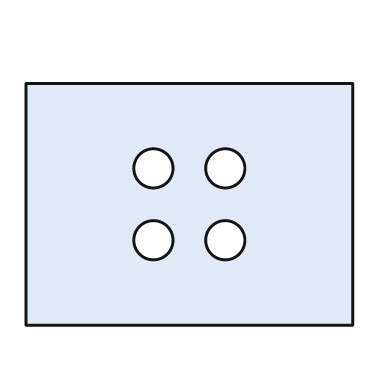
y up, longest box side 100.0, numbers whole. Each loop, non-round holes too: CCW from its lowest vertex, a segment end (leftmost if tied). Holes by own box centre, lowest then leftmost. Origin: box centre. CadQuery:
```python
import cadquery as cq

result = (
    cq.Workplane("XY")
    .moveTo(-50.0, -37.0)
    .lineTo(50.0, -37.0)
    .lineTo(50.0, 37.0)
    .lineTo(-50.0, 37.0)
    .close()
    .moveTo(-11.0, -11.0)
    .circle(6.0)
    .moveTo(11.0, -11.0)
    .circle(6.0)
    .moveTo(-11.0, 11.0)
    .circle(6.0)
    .moveTo(11.0, 11.0)
    .circle(6.0)
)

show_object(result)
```